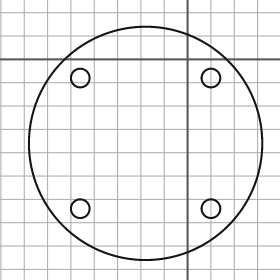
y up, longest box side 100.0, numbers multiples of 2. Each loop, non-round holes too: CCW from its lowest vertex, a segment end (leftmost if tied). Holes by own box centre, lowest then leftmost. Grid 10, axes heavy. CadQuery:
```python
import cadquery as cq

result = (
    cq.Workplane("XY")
    .moveTo(-18.0, -36.0)
    .circle(50.0)
    .moveTo(-46.0, -64.0)
    .circle(4.0)
    .moveTo(10.0, -64.0)
    .circle(4.0)
    .moveTo(-46.0, -8.0)
    .circle(4.0)
    .moveTo(10.0, -8.0)
    .circle(4.0)
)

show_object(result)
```